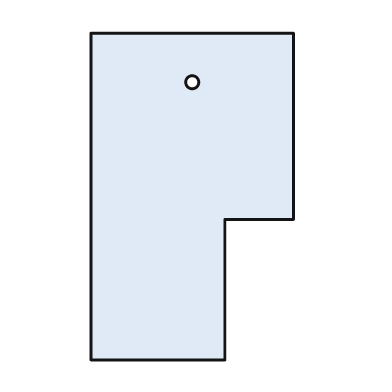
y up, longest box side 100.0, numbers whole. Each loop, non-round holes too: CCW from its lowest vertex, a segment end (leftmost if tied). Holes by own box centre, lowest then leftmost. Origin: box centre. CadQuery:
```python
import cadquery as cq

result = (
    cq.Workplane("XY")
    .moveTo(-31.0, -50.0)
    .lineTo(10.0, -50.0)
    .lineTo(10.0, -7.0)
    .lineTo(31.0, -7.0)
    .lineTo(31.0, 50.0)
    .lineTo(-31.0, 50.0)
    .close()
    .moveTo(0.0, 35.0)
    .circle(2.0)
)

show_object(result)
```